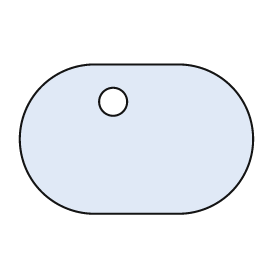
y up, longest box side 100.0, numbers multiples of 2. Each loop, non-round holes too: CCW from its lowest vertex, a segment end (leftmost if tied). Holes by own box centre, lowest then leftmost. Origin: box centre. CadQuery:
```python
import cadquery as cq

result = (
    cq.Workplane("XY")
    .moveTo(-18.0, -32.0)
    .lineTo(18.0, -32.0)
    .threePointArc((50.0, 0.0), (18.0, 32.0))
    .lineTo(-18.0, 32.0)
    .threePointArc((-50.0, 0.0), (-18.0, -32.0))
    .close()
    .moveTo(-10.0, 16.0)
    .circle(6.0)
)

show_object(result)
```